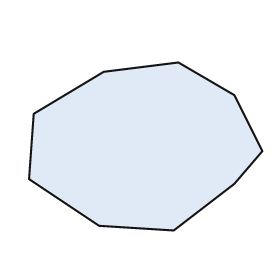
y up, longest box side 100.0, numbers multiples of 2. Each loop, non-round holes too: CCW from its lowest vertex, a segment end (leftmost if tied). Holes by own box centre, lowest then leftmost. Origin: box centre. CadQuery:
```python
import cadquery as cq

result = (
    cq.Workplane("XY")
    .moveTo(12.0, -36.0)
    .lineTo(38.0, -16.0)
    .lineTo(50.0, -2.0)
    .lineTo(38.0, 22.0)
    .lineTo(14.0, 36.0)
    .lineTo(-18.0, 32.0)
    .lineTo(-48.0, 14.0)
    .lineTo(-50.0, -14.0)
    .lineTo(-20.0, -34.0)
    .close()
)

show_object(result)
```